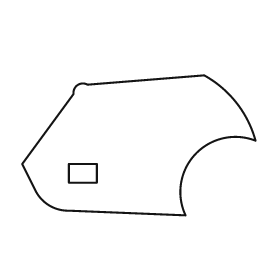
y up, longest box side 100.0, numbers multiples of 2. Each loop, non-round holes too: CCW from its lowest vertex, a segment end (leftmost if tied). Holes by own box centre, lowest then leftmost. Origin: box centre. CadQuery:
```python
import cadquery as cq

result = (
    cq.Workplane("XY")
    .moveTo(20.0, -30.0)
    .threePointArc((24.0, -4.0), (50.0, 2.0))
    .threePointArc((42.0, 18.0), (28.0, 30.0))
    .lineTo(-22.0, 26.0)
    .threePointArc((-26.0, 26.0), (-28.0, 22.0))
    .lineTo(-50.0, -8.0)
    .lineTo(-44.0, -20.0)
    .threePointArc((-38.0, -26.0), (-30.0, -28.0))
    .close()
    .moveTo(-30.0, -16.0)
    .lineTo(-18.0, -16.0)
    .lineTo(-18.0, -8.0)
    .lineTo(-30.0, -8.0)
    .close()
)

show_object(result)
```